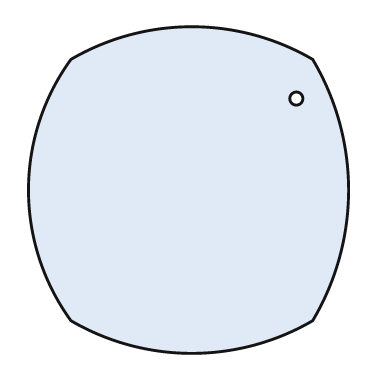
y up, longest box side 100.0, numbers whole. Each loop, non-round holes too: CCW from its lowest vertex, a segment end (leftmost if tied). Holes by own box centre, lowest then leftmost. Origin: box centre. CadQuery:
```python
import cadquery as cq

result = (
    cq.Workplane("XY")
    .moveTo(-36.0, -40.0)
    .threePointArc((1.0, -50.0), (38.0, -40.0))
    .threePointArc((49.0, 0.0), (38.0, 40.0))
    .threePointArc((1.0, 50.0), (-36.0, 40.0))
    .threePointArc((-49.0, 0.0), (-36.0, -40.0))
    .close()
    .moveTo(33.0, 28.0)
    .circle(2.0)
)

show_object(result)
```